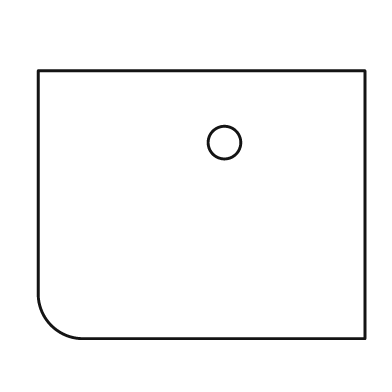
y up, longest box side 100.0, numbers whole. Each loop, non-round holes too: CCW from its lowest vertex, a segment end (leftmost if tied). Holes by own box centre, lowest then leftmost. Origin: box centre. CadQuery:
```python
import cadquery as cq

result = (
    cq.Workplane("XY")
    .moveTo(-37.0, -41.0)
    .lineTo(50.0, -41.0)
    .lineTo(50.0, 41.0)
    .lineTo(-50.0, 41.0)
    .lineTo(-50.0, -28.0)
    .threePointArc((-46.0, -37.0), (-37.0, -41.0))
    .close()
    .moveTo(7.0, 19.0)
    .circle(5.0)
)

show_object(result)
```